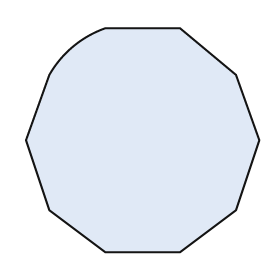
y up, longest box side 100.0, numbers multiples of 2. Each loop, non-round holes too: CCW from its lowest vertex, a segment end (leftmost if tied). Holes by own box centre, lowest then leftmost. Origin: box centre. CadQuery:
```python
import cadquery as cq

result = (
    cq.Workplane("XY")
    .moveTo(-16.0, -48.0)
    .lineTo(16.0, -48.0)
    .lineTo(40.0, -30.0)
    .lineTo(50.0, 0.0)
    .lineTo(40.0, 28.0)
    .lineTo(16.0, 48.0)
    .lineTo(-16.0, 48.0)
    .threePointArc((-30.0, 40.0), (-40.0, 28.0))
    .lineTo(-50.0, 0.0)
    .lineTo(-40.0, -30.0)
    .close()
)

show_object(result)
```